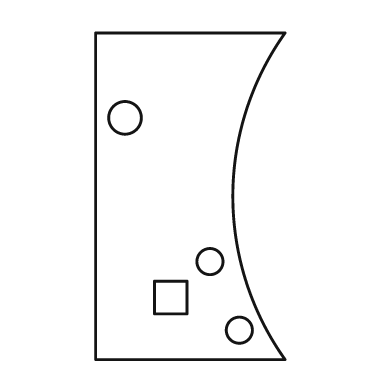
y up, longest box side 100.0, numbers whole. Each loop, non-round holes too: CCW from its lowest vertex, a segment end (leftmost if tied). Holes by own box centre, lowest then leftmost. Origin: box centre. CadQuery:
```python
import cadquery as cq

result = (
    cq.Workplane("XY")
    .moveTo(-29.0, -50.0)
    .lineTo(29.0, -50.0)
    .threePointArc((13.0, 0.0), (29.0, 50.0))
    .lineTo(-29.0, 50.0)
    .close()
    .moveTo(15.0, -41.0)
    .circle(4.0)
    .moveTo(-11.0, -36.0)
    .lineTo(-1.0, -36.0)
    .lineTo(-1.0, -26.0)
    .lineTo(-11.0, -26.0)
    .close()
    .moveTo(6.0, -20.0)
    .circle(4.0)
    .moveTo(-20.0, 24.0)
    .circle(5.0)
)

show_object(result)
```